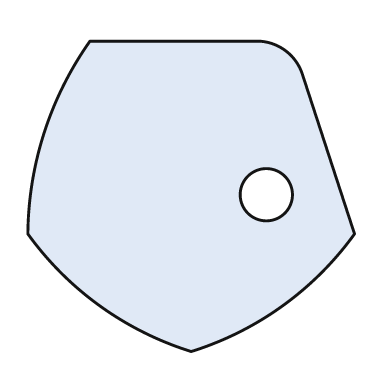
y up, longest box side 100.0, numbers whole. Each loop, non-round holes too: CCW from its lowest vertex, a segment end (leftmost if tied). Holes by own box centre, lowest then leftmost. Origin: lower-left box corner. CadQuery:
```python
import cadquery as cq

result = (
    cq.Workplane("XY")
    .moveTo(50.0, 0.0)
    .threePointArc((78.0, 14.0), (100.0, 36.0))
    .lineTo(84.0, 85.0)
    .threePointArc((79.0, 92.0), (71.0, 95.0))
    .lineTo(19.0, 95.0)
    .threePointArc((5.0, 67.0), (0.0, 36.0))
    .threePointArc((22.0, 14.0), (50.0, 0.0))
    .close()
    .moveTo(73.0, 48.0)
    .circle(8.0)
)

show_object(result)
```